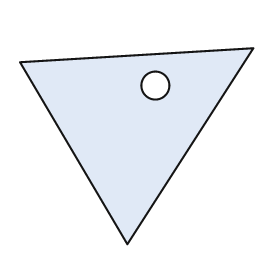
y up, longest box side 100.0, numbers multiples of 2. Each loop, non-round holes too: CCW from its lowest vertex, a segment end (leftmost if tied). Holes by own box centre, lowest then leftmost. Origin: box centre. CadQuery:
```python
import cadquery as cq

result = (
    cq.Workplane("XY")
    .moveTo(-4.0, -42.0)
    .lineTo(50.0, 42.0)
    .lineTo(-50.0, 36.0)
    .close()
    .moveTo(8.0, 26.0)
    .circle(6.0)
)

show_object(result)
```